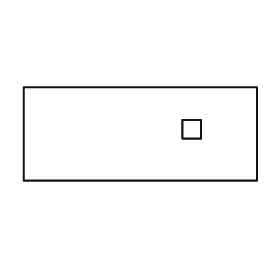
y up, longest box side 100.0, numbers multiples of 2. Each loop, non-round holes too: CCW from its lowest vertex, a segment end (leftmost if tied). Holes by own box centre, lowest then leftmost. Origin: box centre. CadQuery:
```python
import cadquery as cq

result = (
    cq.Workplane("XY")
    .moveTo(-50.0, -20.0)
    .lineTo(50.0, -20.0)
    .lineTo(50.0, 20.0)
    .lineTo(-50.0, 20.0)
    .close()
    .moveTo(18.0, -2.0)
    .lineTo(26.0, -2.0)
    .lineTo(26.0, 6.0)
    .lineTo(18.0, 6.0)
    .close()
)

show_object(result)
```